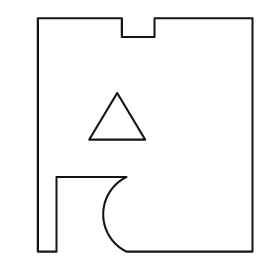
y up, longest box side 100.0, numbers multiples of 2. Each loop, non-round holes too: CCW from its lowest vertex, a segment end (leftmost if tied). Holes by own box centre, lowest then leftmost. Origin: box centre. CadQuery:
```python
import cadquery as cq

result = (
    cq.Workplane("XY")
    .moveTo(-46.0, -50.0)
    .lineTo(-38.0, -50.0)
    .lineTo(-38.0, -18.0)
    .lineTo(-8.0, -18.0)
    .threePointArc((-18.0, -34.0), (-8.0, -50.0))
    .lineTo(46.0, -50.0)
    .lineTo(46.0, 50.0)
    .lineTo(4.0, 50.0)
    .lineTo(4.0, 42.0)
    .lineTo(-10.0, 42.0)
    .lineTo(-10.0, 50.0)
    .lineTo(-46.0, 50.0)
    .close()
    .moveTo(-24.0, -2.0)
    .lineTo(0.0, -2.0)
    .lineTo(-12.0, 18.0)
    .close()
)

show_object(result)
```